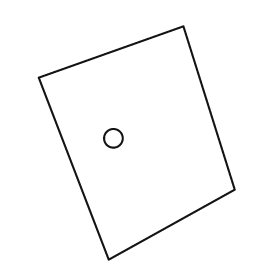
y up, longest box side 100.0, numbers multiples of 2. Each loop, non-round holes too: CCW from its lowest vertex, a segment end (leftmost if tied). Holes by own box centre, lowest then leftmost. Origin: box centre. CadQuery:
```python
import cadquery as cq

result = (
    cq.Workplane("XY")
    .moveTo(-12.0, -50.0)
    .lineTo(42.0, -20.0)
    .lineTo(20.0, 50.0)
    .lineTo(-42.0, 28.0)
    .close()
    .moveTo(-10.0, 2.0)
    .circle(4.0)
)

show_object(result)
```